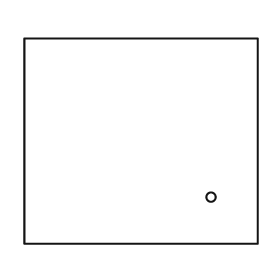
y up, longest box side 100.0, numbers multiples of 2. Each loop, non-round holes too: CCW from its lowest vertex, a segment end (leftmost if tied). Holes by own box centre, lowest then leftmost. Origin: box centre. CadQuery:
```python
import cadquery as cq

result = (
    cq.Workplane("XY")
    .moveTo(-50.0, -44.0)
    .lineTo(50.0, -44.0)
    .lineTo(50.0, 44.0)
    .lineTo(-50.0, 44.0)
    .close()
    .moveTo(30.0, -24.0)
    .circle(2.0)
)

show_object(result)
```